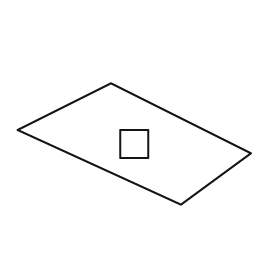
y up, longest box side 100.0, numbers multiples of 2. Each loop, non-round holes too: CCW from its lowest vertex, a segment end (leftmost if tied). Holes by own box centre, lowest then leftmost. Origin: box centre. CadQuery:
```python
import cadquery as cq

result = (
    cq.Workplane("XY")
    .moveTo(20.0, -26.0)
    .lineTo(50.0, -4.0)
    .lineTo(-10.0, 26.0)
    .lineTo(-50.0, 6.0)
    .close()
    .moveTo(-6.0, -6.0)
    .lineTo(6.0, -6.0)
    .lineTo(6.0, 6.0)
    .lineTo(-6.0, 6.0)
    .close()
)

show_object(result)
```